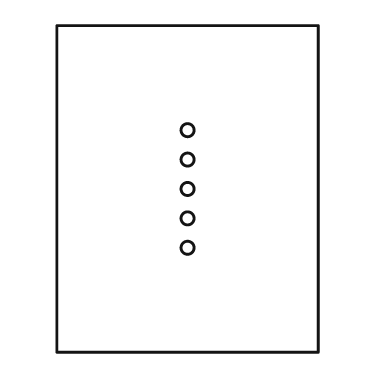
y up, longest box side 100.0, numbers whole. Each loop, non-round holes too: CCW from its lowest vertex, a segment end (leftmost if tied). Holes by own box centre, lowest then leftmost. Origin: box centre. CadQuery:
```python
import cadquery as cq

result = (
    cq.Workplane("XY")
    .moveTo(-40.0, -50.0)
    .lineTo(40.0, -50.0)
    .lineTo(40.0, 50.0)
    .lineTo(-40.0, 50.0)
    .close()
    .moveTo(0.0, -18.0)
    .circle(2.0)
    .moveTo(0.0, -9.0)
    .circle(2.0)
    .moveTo(0.0, 0.0)
    .circle(2.0)
    .moveTo(0.0, 9.0)
    .circle(2.0)
    .moveTo(0.0, 18.0)
    .circle(2.0)
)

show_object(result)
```